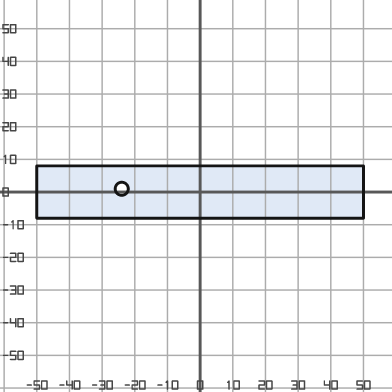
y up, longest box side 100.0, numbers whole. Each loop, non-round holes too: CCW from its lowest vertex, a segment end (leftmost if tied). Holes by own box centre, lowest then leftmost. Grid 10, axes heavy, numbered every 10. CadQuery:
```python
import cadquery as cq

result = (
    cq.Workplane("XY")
    .moveTo(-50.0, -8.0)
    .lineTo(50.0, -8.0)
    .lineTo(50.0, 8.0)
    .lineTo(-50.0, 8.0)
    .close()
    .moveTo(-24.0, 1.0)
    .circle(2.0)
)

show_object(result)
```